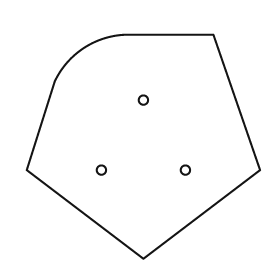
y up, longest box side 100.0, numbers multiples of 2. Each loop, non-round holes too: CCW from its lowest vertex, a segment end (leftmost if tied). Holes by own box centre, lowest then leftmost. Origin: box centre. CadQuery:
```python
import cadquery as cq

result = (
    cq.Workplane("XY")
    .moveTo(0.0, -48.0)
    .lineTo(50.0, -10.0)
    .lineTo(30.0, 48.0)
    .lineTo(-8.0, 48.0)
    .threePointArc((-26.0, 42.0), (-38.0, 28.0))
    .lineTo(-50.0, -10.0)
    .close()
    .moveTo(-18.0, -10.0)
    .circle(2.0)
    .moveTo(18.0, -10.0)
    .circle(2.0)
    .moveTo(0.0, 20.0)
    .circle(2.0)
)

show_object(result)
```